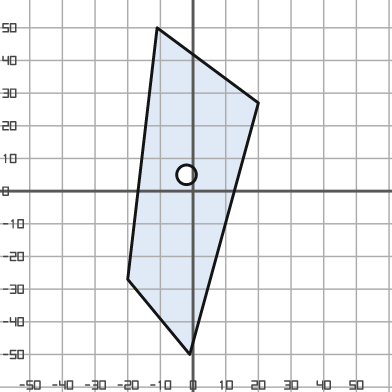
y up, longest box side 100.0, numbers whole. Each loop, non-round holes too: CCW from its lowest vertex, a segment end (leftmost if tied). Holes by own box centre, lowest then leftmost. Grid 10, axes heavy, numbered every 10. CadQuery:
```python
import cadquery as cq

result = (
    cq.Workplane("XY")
    .moveTo(-1.0, -50.0)
    .lineTo(20.0, 27.0)
    .lineTo(-11.0, 50.0)
    .lineTo(-20.0, -27.0)
    .close()
    .moveTo(-2.0, 5.0)
    .circle(3.0)
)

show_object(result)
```